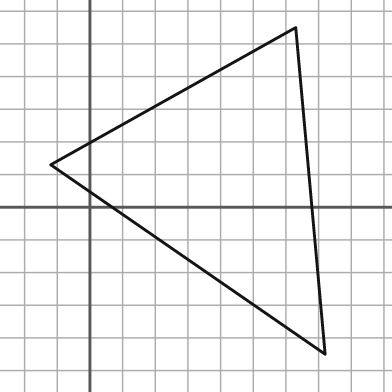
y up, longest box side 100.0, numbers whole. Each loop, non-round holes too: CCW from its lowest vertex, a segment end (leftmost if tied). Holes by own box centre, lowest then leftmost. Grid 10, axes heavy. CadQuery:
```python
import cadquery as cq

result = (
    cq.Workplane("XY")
    .moveTo(72.0, -45.0)
    .lineTo(63.0, 55.0)
    .lineTo(-12.0, 13.0)
    .close()
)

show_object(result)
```